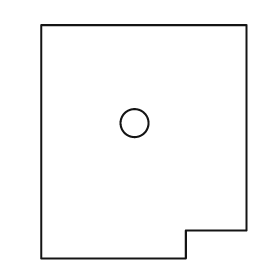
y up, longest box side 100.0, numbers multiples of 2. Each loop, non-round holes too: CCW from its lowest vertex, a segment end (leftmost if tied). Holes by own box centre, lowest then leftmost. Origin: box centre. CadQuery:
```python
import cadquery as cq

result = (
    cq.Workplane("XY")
    .moveTo(-44.0, -50.0)
    .lineTo(18.0, -50.0)
    .lineTo(18.0, -38.0)
    .lineTo(44.0, -38.0)
    .lineTo(44.0, 50.0)
    .lineTo(-44.0, 50.0)
    .close()
    .moveTo(-4.0, 8.0)
    .circle(6.0)
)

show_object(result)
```